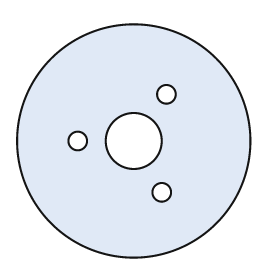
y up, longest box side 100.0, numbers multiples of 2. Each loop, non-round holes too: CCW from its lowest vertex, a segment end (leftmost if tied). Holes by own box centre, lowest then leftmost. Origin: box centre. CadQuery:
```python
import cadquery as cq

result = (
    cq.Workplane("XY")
    .moveTo(0.0, 0.0)
    .circle(50.0)
    .moveTo(12.0, -22.0)
    .circle(4.0)
    .moveTo(-24.0, 0.0)
    .circle(4.0)
    .moveTo(0.0, 0.0)
    .circle(12.0)
    .moveTo(14.0, 20.0)
    .circle(4.0)
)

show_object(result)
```